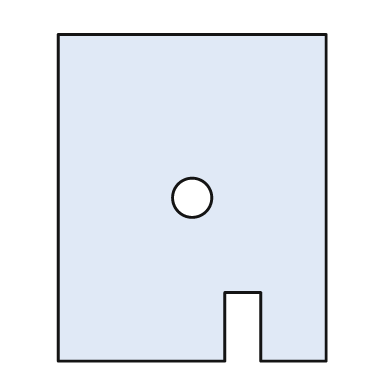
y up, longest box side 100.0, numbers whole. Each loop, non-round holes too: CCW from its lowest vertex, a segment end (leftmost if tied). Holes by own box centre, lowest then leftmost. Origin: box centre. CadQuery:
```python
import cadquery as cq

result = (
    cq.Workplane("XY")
    .moveTo(-41.0, -50.0)
    .lineTo(10.0, -50.0)
    .lineTo(10.0, -29.0)
    .lineTo(21.0, -29.0)
    .lineTo(21.0, -50.0)
    .lineTo(41.0, -50.0)
    .lineTo(41.0, 50.0)
    .lineTo(-41.0, 50.0)
    .close()
    .moveTo(0.0, 0.0)
    .circle(6.0)
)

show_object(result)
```